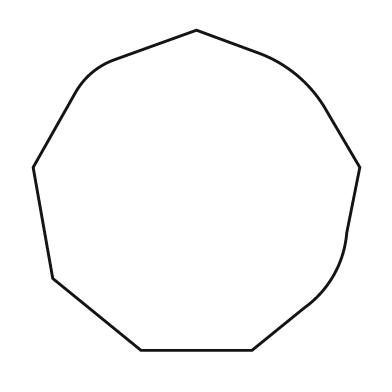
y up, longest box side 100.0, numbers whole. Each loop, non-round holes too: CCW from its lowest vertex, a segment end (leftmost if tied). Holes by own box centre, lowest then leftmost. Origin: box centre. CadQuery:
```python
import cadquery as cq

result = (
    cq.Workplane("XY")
    .moveTo(-17.0, -49.0)
    .lineTo(17.0, -49.0)
    .lineTo(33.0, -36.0)
    .threePointArc((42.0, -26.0), (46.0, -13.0))
    .lineTo(50.0, 7.0)
    .lineTo(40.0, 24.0)
    .threePointArc((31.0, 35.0), (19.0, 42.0))
    .lineTo(0.0, 49.0)
    .lineTo(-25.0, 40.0)
    .threePointArc((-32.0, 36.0), (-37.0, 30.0))
    .lineTo(-50.0, 7.0)
    .lineTo(-44.0, -27.0)
    .close()
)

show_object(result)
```